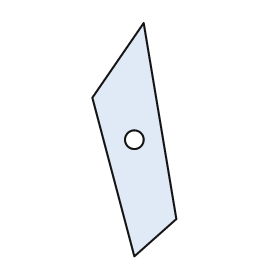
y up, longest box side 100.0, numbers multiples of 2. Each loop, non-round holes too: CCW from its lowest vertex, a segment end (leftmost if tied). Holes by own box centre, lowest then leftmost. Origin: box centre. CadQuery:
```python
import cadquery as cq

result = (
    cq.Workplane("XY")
    .moveTo(0.0, -50.0)
    .lineTo(18.0, -34.0)
    .lineTo(4.0, 50.0)
    .lineTo(-18.0, 18.0)
    .close()
    .moveTo(0.0, 0.0)
    .circle(4.0)
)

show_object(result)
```